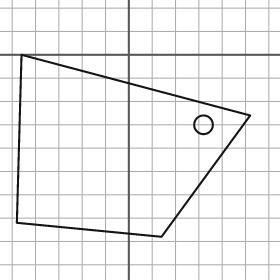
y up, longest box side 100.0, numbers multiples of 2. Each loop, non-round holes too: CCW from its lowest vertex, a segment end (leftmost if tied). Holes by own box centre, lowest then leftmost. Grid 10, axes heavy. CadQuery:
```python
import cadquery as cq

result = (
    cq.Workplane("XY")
    .moveTo(14.0, -78.0)
    .lineTo(52.0, -26.0)
    .lineTo(-46.0, 0.0)
    .lineTo(-48.0, -72.0)
    .close()
    .moveTo(32.0, -30.0)
    .circle(4.0)
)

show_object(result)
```